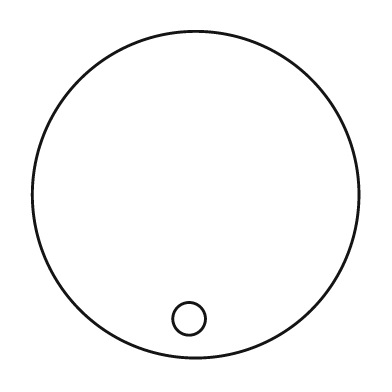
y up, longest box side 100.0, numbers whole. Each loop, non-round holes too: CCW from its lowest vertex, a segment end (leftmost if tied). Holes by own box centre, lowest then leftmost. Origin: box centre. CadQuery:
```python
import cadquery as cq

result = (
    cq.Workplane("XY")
    .moveTo(0.0, 0.0)
    .circle(50.0)
    .moveTo(-2.0, -38.0)
    .circle(5.0)
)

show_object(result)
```